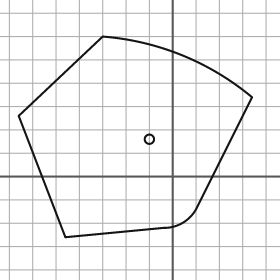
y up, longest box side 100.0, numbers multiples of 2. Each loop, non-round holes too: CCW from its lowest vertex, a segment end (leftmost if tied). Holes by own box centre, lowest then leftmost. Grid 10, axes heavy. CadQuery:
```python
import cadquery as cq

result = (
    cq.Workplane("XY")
    .moveTo(-46.0, -26.0)
    .lineTo(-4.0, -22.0)
    .threePointArc((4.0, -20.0), (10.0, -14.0))
    .lineTo(34.0, 34.0)
    .threePointArc((4.0, 52.0), (-30.0, 60.0))
    .lineTo(-66.0, 26.0)
    .close()
    .moveTo(-10.0, 16.0)
    .circle(2.0)
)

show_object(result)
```